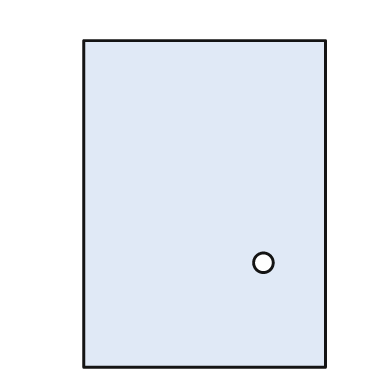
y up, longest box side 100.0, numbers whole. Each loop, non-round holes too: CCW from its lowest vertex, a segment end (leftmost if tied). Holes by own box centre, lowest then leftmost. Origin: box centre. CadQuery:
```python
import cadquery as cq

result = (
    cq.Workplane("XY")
    .moveTo(-37.0, -50.0)
    .lineTo(37.0, -50.0)
    .lineTo(37.0, 50.0)
    .lineTo(-37.0, 50.0)
    .close()
    .moveTo(18.0, -18.0)
    .circle(3.0)
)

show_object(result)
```